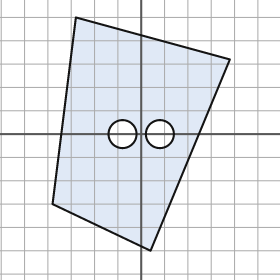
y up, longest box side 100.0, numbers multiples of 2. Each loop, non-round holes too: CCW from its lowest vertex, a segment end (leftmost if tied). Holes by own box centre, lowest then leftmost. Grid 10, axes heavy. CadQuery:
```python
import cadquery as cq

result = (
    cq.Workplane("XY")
    .moveTo(4.0, -50.0)
    .lineTo(38.0, 32.0)
    .lineTo(-28.0, 50.0)
    .lineTo(-38.0, -30.0)
    .close()
    .moveTo(-8.0, 0.0)
    .circle(6.0)
    .moveTo(8.0, 0.0)
    .circle(6.0)
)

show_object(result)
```